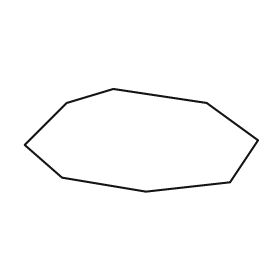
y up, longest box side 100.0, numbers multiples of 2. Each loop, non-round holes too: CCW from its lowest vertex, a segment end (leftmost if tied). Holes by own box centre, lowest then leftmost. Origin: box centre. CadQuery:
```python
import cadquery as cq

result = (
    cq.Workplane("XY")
    .moveTo(2.0, -22.0)
    .lineTo(38.0, -18.0)
    .lineTo(50.0, 0.0)
    .lineTo(28.0, 16.0)
    .lineTo(-12.0, 22.0)
    .lineTo(-32.0, 16.0)
    .lineTo(-50.0, -2.0)
    .lineTo(-34.0, -16.0)
    .close()
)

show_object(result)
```